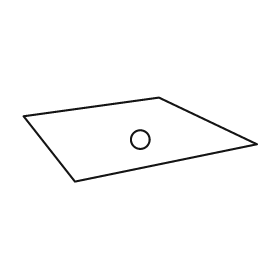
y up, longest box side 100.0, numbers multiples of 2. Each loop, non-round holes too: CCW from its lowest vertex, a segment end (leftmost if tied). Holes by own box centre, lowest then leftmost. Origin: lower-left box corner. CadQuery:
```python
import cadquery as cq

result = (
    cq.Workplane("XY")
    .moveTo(22.0, 0.0)
    .lineTo(100.0, 16.0)
    .lineTo(58.0, 36.0)
    .lineTo(0.0, 28.0)
    .close()
    .moveTo(50.0, 18.0)
    .circle(4.0)
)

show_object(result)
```